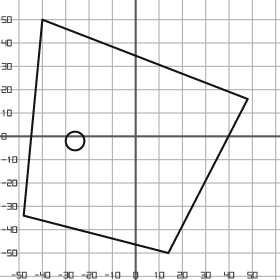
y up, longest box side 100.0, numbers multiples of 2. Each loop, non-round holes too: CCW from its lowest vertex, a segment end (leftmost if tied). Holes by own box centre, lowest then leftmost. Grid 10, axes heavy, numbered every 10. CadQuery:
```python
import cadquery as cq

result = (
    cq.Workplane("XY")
    .moveTo(14.0, -50.0)
    .lineTo(48.0, 16.0)
    .lineTo(-40.0, 50.0)
    .lineTo(-48.0, -34.0)
    .close()
    .moveTo(-26.0, -2.0)
    .circle(4.0)
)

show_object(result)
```